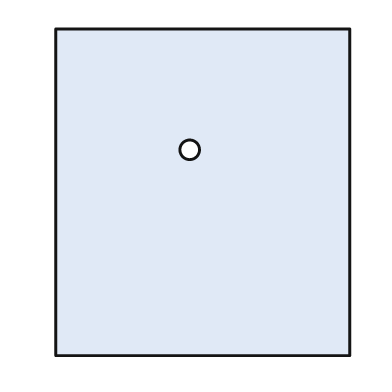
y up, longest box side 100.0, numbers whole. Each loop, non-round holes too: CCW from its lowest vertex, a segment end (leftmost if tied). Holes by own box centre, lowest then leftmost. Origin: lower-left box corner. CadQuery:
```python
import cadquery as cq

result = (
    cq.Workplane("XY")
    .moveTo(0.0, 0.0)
    .lineTo(90.0, 0.0)
    .lineTo(90.0, 100.0)
    .lineTo(0.0, 100.0)
    .close()
    .moveTo(41.0, 63.0)
    .circle(3.0)
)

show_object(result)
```